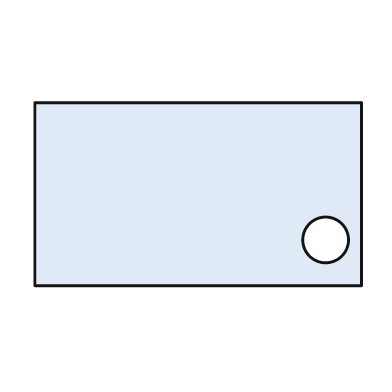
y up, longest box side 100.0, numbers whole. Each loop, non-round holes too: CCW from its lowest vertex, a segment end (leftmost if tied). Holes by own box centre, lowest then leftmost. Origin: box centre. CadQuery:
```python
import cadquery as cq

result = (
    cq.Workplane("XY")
    .moveTo(-50.0, -28.0)
    .lineTo(50.0, -28.0)
    .lineTo(50.0, 28.0)
    .lineTo(-50.0, 28.0)
    .close()
    .moveTo(39.0, -14.0)
    .circle(7.0)
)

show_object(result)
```